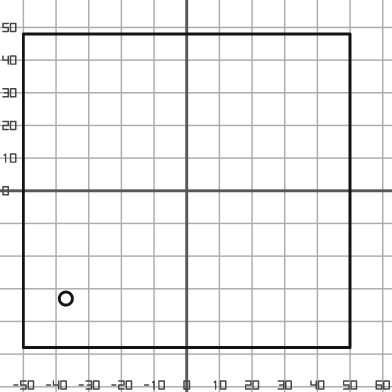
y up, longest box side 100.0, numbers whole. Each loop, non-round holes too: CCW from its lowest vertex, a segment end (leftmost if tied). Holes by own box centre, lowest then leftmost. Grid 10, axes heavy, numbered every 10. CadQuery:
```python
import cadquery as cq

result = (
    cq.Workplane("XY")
    .moveTo(-50.0, -48.0)
    .lineTo(50.0, -48.0)
    .lineTo(50.0, 48.0)
    .lineTo(-50.0, 48.0)
    .close()
    .moveTo(-37.0, -33.0)
    .circle(2.0)
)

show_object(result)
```